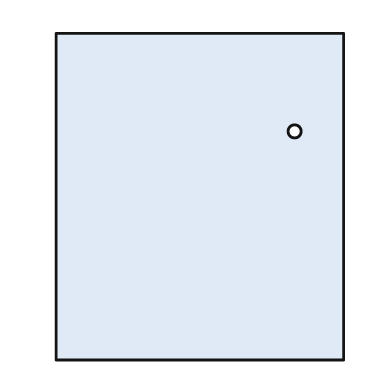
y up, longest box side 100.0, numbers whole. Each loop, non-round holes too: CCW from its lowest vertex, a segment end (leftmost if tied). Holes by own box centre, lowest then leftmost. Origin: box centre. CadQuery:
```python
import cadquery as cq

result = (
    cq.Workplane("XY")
    .moveTo(-44.0, -50.0)
    .lineTo(44.0, -50.0)
    .lineTo(44.0, 50.0)
    .lineTo(-44.0, 50.0)
    .close()
    .moveTo(29.0, 20.0)
    .circle(2.0)
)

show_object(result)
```